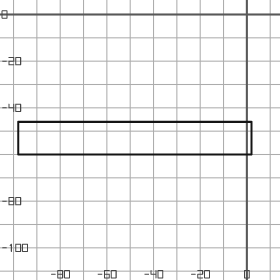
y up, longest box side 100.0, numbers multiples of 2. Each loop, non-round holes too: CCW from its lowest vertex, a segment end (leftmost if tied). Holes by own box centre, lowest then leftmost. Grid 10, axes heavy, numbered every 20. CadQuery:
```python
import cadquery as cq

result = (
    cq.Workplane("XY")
    .moveTo(-98.0, -60.0)
    .lineTo(2.0, -60.0)
    .lineTo(2.0, -46.0)
    .lineTo(-98.0, -46.0)
    .close()
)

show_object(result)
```